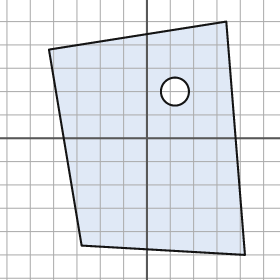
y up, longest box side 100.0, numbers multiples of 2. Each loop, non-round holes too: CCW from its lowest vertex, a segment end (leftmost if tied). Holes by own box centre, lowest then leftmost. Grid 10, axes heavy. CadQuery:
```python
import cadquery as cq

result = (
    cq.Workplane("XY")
    .moveTo(42.0, -50.0)
    .lineTo(34.0, 50.0)
    .lineTo(-42.0, 38.0)
    .lineTo(-28.0, -46.0)
    .close()
    .moveTo(12.0, 20.0)
    .circle(6.0)
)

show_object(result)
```